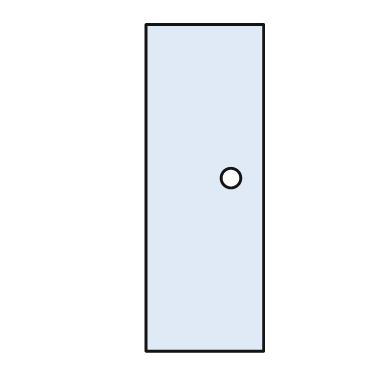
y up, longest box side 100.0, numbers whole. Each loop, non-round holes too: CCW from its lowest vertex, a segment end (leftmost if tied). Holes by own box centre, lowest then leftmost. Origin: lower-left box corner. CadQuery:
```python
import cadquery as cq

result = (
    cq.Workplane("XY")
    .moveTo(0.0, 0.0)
    .lineTo(36.0, 0.0)
    .lineTo(36.0, 100.0)
    .lineTo(0.0, 100.0)
    .close()
    .moveTo(26.0, 53.0)
    .circle(3.0)
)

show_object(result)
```